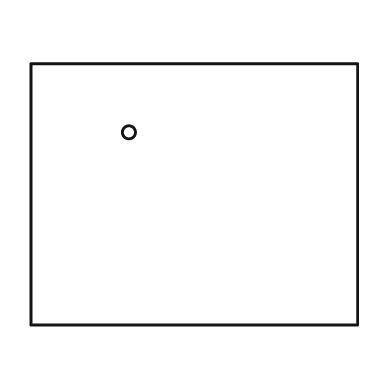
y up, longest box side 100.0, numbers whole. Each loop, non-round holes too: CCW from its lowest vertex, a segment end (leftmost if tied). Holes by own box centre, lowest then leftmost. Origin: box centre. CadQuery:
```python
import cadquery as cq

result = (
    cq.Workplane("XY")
    .moveTo(-50.0, -40.0)
    .lineTo(50.0, -40.0)
    .lineTo(50.0, 40.0)
    .lineTo(-50.0, 40.0)
    .close()
    .moveTo(-20.0, 19.0)
    .circle(2.0)
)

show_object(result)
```